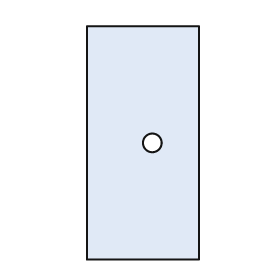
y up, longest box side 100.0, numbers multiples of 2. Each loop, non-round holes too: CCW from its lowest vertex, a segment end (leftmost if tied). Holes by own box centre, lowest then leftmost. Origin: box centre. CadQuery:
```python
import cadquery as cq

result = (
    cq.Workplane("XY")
    .moveTo(-24.0, -50.0)
    .lineTo(24.0, -50.0)
    .lineTo(24.0, 50.0)
    .lineTo(-24.0, 50.0)
    .close()
    .moveTo(4.0, 0.0)
    .circle(4.0)
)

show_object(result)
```